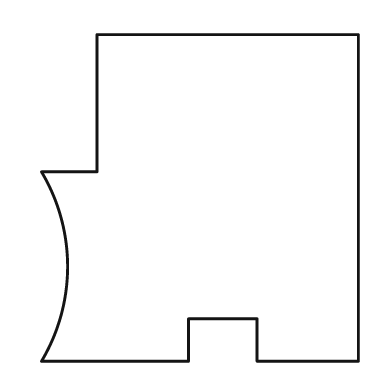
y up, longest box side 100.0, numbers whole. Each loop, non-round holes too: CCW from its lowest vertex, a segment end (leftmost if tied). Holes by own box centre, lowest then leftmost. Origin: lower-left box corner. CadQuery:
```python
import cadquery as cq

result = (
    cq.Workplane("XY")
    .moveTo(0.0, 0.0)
    .lineTo(45.0, 0.0)
    .lineTo(45.0, 13.0)
    .lineTo(66.0, 13.0)
    .lineTo(66.0, 0.0)
    .lineTo(97.0, 0.0)
    .lineTo(97.0, 100.0)
    .lineTo(17.0, 100.0)
    .lineTo(17.0, 58.0)
    .lineTo(0.0, 58.0)
    .threePointArc((8.0, 29.0), (0.0, 0.0))
    .close()
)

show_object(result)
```